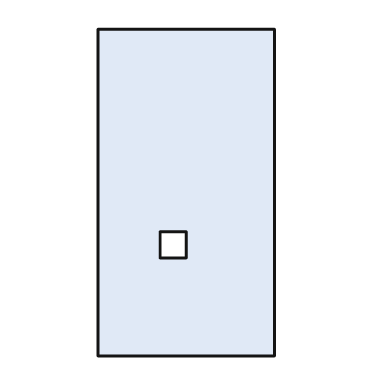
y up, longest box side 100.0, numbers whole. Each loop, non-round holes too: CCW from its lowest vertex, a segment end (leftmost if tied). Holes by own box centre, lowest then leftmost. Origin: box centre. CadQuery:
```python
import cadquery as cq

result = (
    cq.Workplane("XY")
    .moveTo(-27.0, -50.0)
    .lineTo(27.0, -50.0)
    .lineTo(27.0, 50.0)
    .lineTo(-27.0, 50.0)
    .close()
    .moveTo(-8.0, -20.0)
    .lineTo(0.0, -20.0)
    .lineTo(0.0, -12.0)
    .lineTo(-8.0, -12.0)
    .close()
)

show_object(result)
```